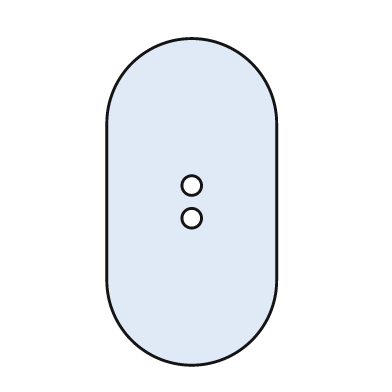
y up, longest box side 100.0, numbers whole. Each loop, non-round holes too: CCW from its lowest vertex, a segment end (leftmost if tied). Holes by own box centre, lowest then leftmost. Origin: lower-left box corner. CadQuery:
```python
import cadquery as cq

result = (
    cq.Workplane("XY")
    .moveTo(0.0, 26.0)
    .threePointArc((26.0, 0.0), (52.0, 26.0))
    .lineTo(52.0, 74.0)
    .threePointArc((26.0, 100.0), (0.0, 74.0))
    .close()
    .moveTo(26.0, 45.0)
    .circle(3.0)
    .moveTo(26.0, 55.0)
    .circle(3.0)
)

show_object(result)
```